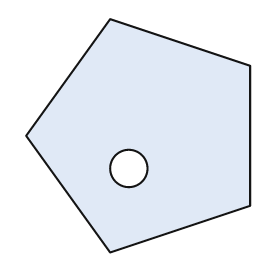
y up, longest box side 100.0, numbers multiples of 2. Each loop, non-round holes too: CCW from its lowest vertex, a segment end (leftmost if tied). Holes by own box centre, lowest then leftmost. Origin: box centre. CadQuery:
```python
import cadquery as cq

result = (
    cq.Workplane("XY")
    .moveTo(-12.0, -50.0)
    .lineTo(48.0, -30.0)
    .lineTo(48.0, 30.0)
    .lineTo(-12.0, 50.0)
    .lineTo(-48.0, 0.0)
    .close()
    .moveTo(-4.0, -14.0)
    .circle(8.0)
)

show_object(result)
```